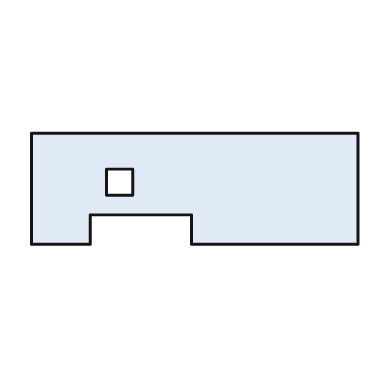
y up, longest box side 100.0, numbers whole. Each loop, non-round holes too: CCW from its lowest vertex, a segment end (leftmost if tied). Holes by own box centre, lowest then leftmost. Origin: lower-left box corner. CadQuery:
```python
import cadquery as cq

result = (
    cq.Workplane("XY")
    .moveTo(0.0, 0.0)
    .lineTo(18.0, 0.0)
    .lineTo(18.0, 9.0)
    .lineTo(49.0, 9.0)
    .lineTo(49.0, 0.0)
    .lineTo(100.0, 0.0)
    .lineTo(100.0, 34.0)
    .lineTo(0.0, 34.0)
    .close()
    .moveTo(23.0, 15.0)
    .lineTo(31.0, 15.0)
    .lineTo(31.0, 23.0)
    .lineTo(23.0, 23.0)
    .close()
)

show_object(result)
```